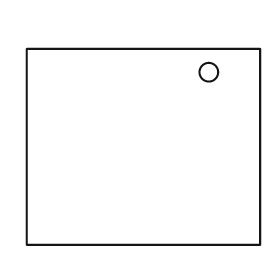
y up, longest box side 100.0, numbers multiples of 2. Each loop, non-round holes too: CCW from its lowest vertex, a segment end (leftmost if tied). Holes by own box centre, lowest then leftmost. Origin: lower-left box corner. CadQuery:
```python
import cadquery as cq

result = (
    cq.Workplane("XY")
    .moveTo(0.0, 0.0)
    .lineTo(100.0, 0.0)
    .lineTo(100.0, 84.0)
    .lineTo(0.0, 84.0)
    .close()
    .moveTo(78.0, 74.0)
    .circle(4.0)
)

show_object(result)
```